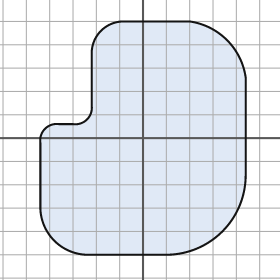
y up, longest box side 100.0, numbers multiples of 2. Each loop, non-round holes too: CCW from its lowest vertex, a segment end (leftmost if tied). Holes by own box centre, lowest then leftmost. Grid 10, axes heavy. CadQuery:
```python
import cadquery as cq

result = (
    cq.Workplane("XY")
    .moveTo(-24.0, -50.0)
    .lineTo(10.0, -50.0)
    .threePointArc((34.0, -40.0), (44.0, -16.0))
    .lineTo(44.0, 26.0)
    .threePointArc((36.0, 42.0), (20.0, 50.0))
    .lineTo(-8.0, 50.0)
    .threePointArc((-18.0, 46.0), (-22.0, 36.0))
    .lineTo(-22.0, 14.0)
    .threePointArc((-24.0, 8.0), (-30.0, 6.0))
    .lineTo(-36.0, 6.0)
    .threePointArc((-42.0, 4.0), (-44.0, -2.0))
    .lineTo(-44.0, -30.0)
    .threePointArc((-38.0, -44.0), (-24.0, -50.0))
    .close()
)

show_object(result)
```